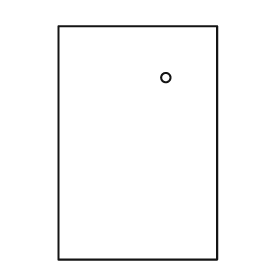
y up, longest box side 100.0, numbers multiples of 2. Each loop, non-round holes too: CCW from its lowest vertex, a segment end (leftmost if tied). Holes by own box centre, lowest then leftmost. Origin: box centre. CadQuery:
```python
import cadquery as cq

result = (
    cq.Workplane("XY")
    .moveTo(-34.0, -50.0)
    .lineTo(34.0, -50.0)
    .lineTo(34.0, 50.0)
    .lineTo(-34.0, 50.0)
    .close()
    .moveTo(12.0, 28.0)
    .circle(2.0)
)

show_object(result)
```